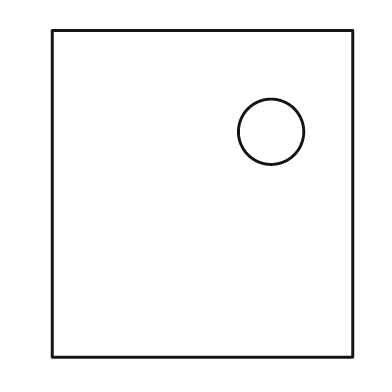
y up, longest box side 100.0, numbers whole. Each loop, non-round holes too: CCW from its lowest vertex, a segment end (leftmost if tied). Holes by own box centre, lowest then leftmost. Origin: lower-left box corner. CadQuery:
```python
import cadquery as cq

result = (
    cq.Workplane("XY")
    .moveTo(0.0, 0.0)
    .lineTo(92.0, 0.0)
    .lineTo(92.0, 100.0)
    .lineTo(0.0, 100.0)
    .close()
    .moveTo(67.0, 69.0)
    .circle(10.0)
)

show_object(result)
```